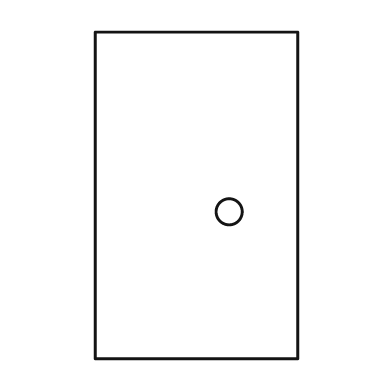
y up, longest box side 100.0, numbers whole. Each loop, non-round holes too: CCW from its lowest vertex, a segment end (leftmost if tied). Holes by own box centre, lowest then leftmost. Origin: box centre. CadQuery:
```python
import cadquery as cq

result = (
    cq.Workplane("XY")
    .moveTo(-31.0, -50.0)
    .lineTo(31.0, -50.0)
    .lineTo(31.0, 50.0)
    .lineTo(-31.0, 50.0)
    .close()
    .moveTo(10.0, -5.0)
    .circle(4.0)
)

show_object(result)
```